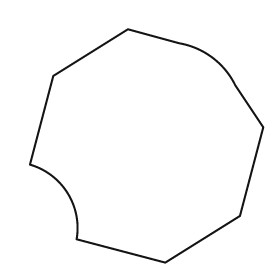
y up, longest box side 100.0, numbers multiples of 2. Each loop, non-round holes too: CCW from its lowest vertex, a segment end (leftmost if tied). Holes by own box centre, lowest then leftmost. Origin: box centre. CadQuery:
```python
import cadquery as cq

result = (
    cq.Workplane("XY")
    .moveTo(8.0, -50.0)
    .lineTo(40.0, -30.0)
    .lineTo(50.0, 8.0)
    .lineTo(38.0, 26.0)
    .threePointArc((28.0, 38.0), (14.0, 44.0))
    .lineTo(-8.0, 50.0)
    .lineTo(-40.0, 30.0)
    .lineTo(-50.0, -8.0)
    .threePointArc((-34.0, -20.0), (-30.0, -40.0))
    .close()
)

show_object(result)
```